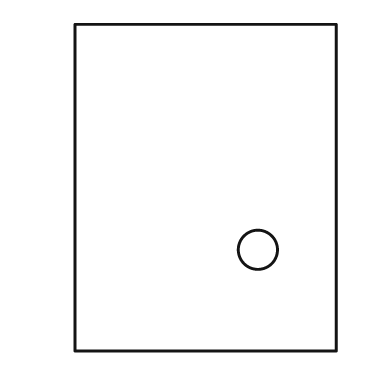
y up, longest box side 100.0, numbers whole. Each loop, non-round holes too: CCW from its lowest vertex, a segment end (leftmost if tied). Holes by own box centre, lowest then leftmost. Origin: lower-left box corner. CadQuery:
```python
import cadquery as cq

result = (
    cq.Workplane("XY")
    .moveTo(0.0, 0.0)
    .lineTo(80.0, 0.0)
    .lineTo(80.0, 100.0)
    .lineTo(0.0, 100.0)
    .close()
    .moveTo(56.0, 31.0)
    .circle(6.0)
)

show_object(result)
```